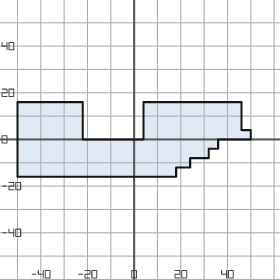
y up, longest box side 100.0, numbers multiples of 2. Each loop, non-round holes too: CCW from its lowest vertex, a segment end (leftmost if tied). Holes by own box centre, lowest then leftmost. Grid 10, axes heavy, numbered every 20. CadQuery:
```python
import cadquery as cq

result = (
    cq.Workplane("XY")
    .moveTo(-50.0, -16.0)
    .lineTo(18.0, -16.0)
    .lineTo(18.0, -12.0)
    .lineTo(24.0, -12.0)
    .lineTo(24.0, -8.0)
    .lineTo(32.0, -8.0)
    .lineTo(32.0, -4.0)
    .lineTo(36.0, -4.0)
    .lineTo(36.0, 0.0)
    .lineTo(50.0, 0.0)
    .lineTo(50.0, 4.0)
    .lineTo(46.0, 4.0)
    .lineTo(46.0, 16.0)
    .lineTo(4.0, 16.0)
    .lineTo(4.0, 0.0)
    .lineTo(-22.0, 0.0)
    .lineTo(-22.0, 16.0)
    .lineTo(-50.0, 16.0)
    .close()
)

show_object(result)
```